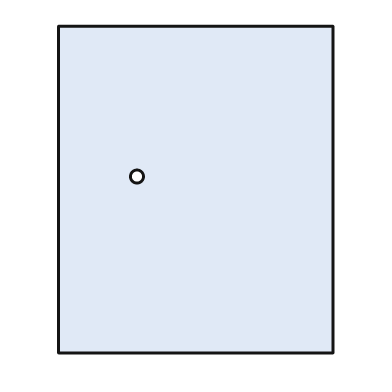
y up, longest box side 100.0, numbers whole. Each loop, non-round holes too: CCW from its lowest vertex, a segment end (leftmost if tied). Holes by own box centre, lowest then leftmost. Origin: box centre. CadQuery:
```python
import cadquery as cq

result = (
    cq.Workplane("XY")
    .moveTo(-42.0, -50.0)
    .lineTo(42.0, -50.0)
    .lineTo(42.0, 50.0)
    .lineTo(-42.0, 50.0)
    .close()
    .moveTo(-18.0, 4.0)
    .circle(2.0)
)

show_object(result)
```